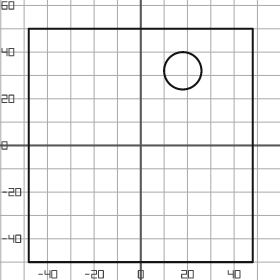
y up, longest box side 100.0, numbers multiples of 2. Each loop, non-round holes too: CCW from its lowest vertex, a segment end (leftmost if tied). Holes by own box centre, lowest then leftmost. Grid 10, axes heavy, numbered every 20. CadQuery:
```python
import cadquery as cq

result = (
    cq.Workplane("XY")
    .moveTo(-48.0, -50.0)
    .lineTo(48.0, -50.0)
    .lineTo(48.0, 50.0)
    .lineTo(-48.0, 50.0)
    .close()
    .moveTo(18.0, 32.0)
    .circle(8.0)
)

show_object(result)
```